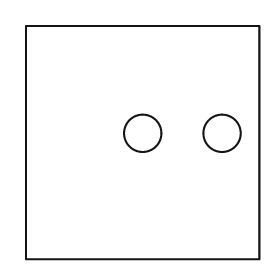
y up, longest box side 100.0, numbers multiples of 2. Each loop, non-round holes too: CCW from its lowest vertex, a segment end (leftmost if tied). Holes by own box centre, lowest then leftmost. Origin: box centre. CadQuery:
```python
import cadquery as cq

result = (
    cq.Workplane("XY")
    .moveTo(-50.0, -50.0)
    .lineTo(50.0, -50.0)
    .lineTo(50.0, 50.0)
    .lineTo(-50.0, 50.0)
    .close()
    .moveTo(0.0, 4.0)
    .circle(8.0)
    .moveTo(34.0, 4.0)
    .circle(8.0)
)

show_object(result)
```